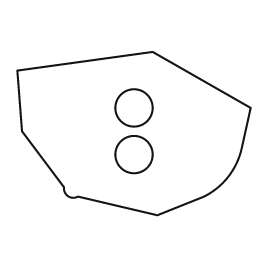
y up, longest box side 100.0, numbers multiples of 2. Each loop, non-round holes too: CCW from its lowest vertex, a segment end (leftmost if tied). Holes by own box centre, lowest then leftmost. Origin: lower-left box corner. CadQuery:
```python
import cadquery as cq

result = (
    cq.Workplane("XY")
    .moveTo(60.0, 0.0)
    .lineTo(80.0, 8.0)
    .threePointArc((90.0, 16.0), (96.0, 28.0))
    .lineTo(100.0, 46.0)
    .lineTo(58.0, 70.0)
    .lineTo(0.0, 62.0)
    .lineTo(2.0, 36.0)
    .lineTo(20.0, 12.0)
    .threePointArc((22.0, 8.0), (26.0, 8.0))
    .close()
    .moveTo(50.0, 26.0)
    .circle(8.0)
    .moveTo(50.0, 46.0)
    .circle(8.0)
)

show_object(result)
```